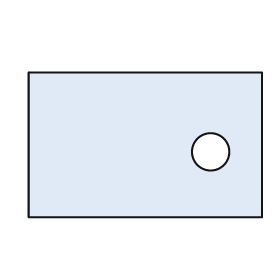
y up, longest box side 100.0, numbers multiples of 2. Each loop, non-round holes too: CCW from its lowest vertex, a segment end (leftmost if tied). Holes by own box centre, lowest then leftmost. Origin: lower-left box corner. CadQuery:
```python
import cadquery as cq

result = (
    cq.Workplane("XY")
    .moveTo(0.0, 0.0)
    .lineTo(100.0, 0.0)
    .lineTo(100.0, 62.0)
    .lineTo(0.0, 62.0)
    .close()
    .moveTo(78.0, 28.0)
    .circle(8.0)
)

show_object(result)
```